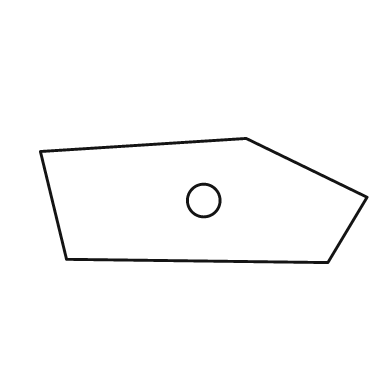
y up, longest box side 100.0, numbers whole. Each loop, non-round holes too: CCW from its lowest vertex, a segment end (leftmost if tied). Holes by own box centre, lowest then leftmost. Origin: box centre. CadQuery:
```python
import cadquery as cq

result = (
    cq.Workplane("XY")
    .moveTo(38.0, -19.0)
    .lineTo(50.0, 1.0)
    .lineTo(13.0, 19.0)
    .lineTo(-50.0, 15.0)
    .lineTo(-42.0, -18.0)
    .close()
    .moveTo(0.0, 0.0)
    .circle(5.0)
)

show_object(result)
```